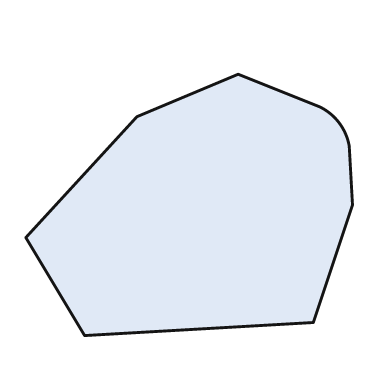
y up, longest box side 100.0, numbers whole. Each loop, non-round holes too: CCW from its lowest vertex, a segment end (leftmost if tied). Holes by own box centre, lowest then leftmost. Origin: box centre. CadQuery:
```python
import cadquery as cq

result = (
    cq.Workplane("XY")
    .moveTo(-32.0, -40.0)
    .lineTo(38.0, -36.0)
    .lineTo(50.0, 0.0)
    .lineTo(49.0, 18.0)
    .threePointArc((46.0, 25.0), (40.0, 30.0))
    .lineTo(15.0, 40.0)
    .lineTo(-16.0, 27.0)
    .lineTo(-50.0, -10.0)
    .close()
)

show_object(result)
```